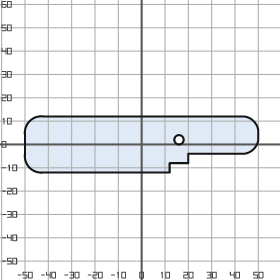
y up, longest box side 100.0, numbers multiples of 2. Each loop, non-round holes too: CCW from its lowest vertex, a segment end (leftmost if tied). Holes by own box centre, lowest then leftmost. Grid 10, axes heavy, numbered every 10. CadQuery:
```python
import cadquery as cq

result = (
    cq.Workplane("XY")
    .moveTo(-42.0, -12.0)
    .lineTo(12.0, -12.0)
    .lineTo(12.0, -8.0)
    .lineTo(20.0, -8.0)
    .lineTo(20.0, -4.0)
    .lineTo(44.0, -4.0)
    .threePointArc((48.0, -2.0), (50.0, 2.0))
    .lineTo(50.0, 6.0)
    .threePointArc((48.0, 10.0), (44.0, 12.0))
    .lineTo(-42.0, 12.0)
    .threePointArc((-48.0, 10.0), (-50.0, 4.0))
    .lineTo(-50.0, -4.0)
    .threePointArc((-48.0, -10.0), (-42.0, -12.0))
    .close()
    .moveTo(16.0, 2.0)
    .circle(2.0)
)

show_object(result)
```